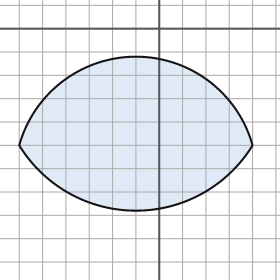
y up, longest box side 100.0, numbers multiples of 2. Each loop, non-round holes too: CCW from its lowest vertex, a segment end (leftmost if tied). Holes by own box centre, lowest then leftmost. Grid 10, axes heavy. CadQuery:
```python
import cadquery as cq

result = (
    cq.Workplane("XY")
    .moveTo(-60.0, -50.0)
    .threePointArc((-10.0, -78.0), (40.0, -50.0))
    .threePointArc((-10.0, -12.0), (-60.0, -50.0))
    .close()
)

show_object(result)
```